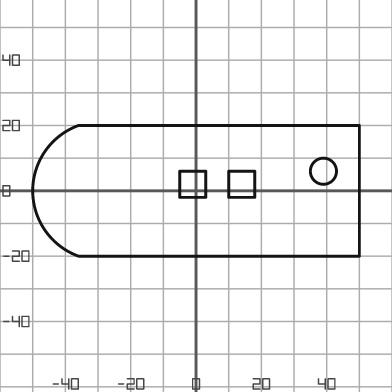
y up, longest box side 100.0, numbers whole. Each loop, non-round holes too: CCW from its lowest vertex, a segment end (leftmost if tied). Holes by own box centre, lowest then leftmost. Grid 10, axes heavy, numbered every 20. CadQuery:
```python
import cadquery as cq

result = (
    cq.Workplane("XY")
    .moveTo(-36.0, -20.0)
    .lineTo(50.0, -20.0)
    .lineTo(50.0, 20.0)
    .lineTo(-36.0, 20.0)
    .threePointArc((-50.0, 0.0), (-36.0, -20.0))
    .close()
    .moveTo(-5.0, -2.0)
    .lineTo(3.0, -2.0)
    .lineTo(3.0, 6.0)
    .lineTo(-5.0, 6.0)
    .close()
    .moveTo(10.0, -2.0)
    .lineTo(18.0, -2.0)
    .lineTo(18.0, 6.0)
    .lineTo(10.0, 6.0)
    .close()
    .moveTo(39.0, 6.0)
    .circle(4.0)
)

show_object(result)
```